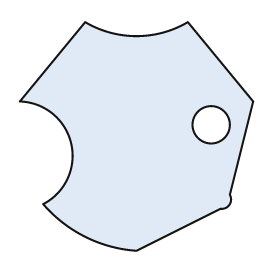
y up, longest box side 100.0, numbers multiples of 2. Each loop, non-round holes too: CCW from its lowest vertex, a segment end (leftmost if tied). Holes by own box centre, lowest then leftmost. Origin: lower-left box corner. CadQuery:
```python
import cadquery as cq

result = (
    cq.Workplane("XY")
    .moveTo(50.0, 0.0)
    .lineTo(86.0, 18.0)
    .threePointArc((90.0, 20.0), (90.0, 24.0))
    .lineTo(100.0, 64.0)
    .lineTo(72.0, 98.0)
    .threePointArc((50.0, 92.0), (28.0, 98.0))
    .lineTo(0.0, 64.0)
    .threePointArc((22.0, 46.0), (10.0, 20.0))
    .threePointArc((28.0, 6.0), (50.0, 0.0))
    .close()
    .moveTo(82.0, 54.0)
    .circle(8.0)
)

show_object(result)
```